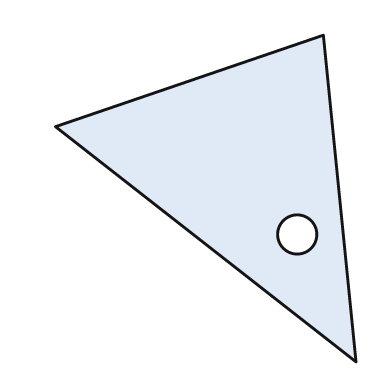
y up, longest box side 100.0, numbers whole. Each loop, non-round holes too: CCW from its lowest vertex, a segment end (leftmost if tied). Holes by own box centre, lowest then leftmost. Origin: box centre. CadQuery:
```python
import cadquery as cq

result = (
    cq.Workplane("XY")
    .moveTo(46.0, -50.0)
    .lineTo(36.0, 50.0)
    .lineTo(-46.0, 22.0)
    .close()
    .moveTo(28.0, -11.0)
    .circle(6.0)
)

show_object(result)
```